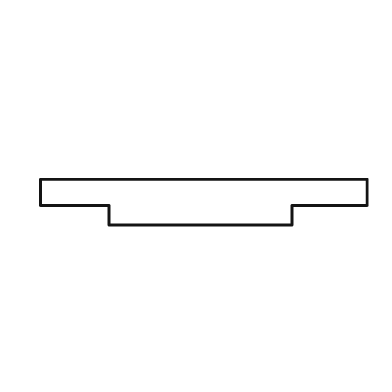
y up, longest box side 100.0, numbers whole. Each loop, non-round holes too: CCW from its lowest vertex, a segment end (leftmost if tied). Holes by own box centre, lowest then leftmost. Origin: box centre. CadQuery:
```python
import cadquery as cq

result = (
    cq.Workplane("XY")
    .moveTo(-29.0, -7.0)
    .lineTo(27.0, -7.0)
    .lineTo(27.0, -1.0)
    .lineTo(50.0, -1.0)
    .lineTo(50.0, 7.0)
    .lineTo(-50.0, 7.0)
    .lineTo(-50.0, -1.0)
    .lineTo(-29.0, -1.0)
    .close()
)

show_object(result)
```